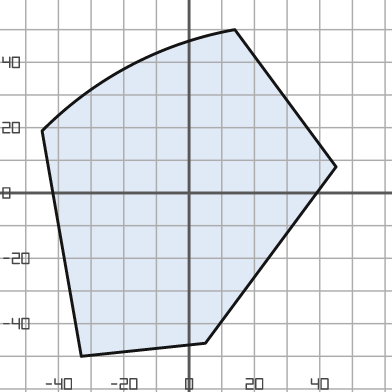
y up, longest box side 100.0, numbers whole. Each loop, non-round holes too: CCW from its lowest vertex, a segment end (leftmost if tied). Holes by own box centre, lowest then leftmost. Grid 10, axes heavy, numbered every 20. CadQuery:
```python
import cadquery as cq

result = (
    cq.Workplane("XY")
    .moveTo(-33.0, -50.0)
    .lineTo(5.0, -46.0)
    .lineTo(45.0, 8.0)
    .lineTo(14.0, 50.0)
    .threePointArc((-18.0, 39.0), (-45.0, 19.0))
    .close()
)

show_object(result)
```